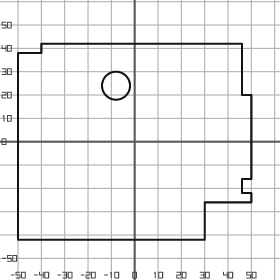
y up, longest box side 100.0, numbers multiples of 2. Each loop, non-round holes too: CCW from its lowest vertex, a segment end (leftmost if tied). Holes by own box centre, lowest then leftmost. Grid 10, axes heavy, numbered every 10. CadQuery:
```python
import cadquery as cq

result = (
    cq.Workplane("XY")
    .moveTo(-50.0, -42.0)
    .lineTo(30.0, -42.0)
    .lineTo(30.0, -26.0)
    .lineTo(50.0, -26.0)
    .lineTo(50.0, -22.0)
    .lineTo(46.0, -22.0)
    .lineTo(46.0, -16.0)
    .lineTo(50.0, -16.0)
    .lineTo(50.0, 20.0)
    .lineTo(46.0, 20.0)
    .lineTo(46.0, 42.0)
    .lineTo(-40.0, 42.0)
    .lineTo(-40.0, 38.0)
    .lineTo(-50.0, 38.0)
    .close()
    .moveTo(-8.0, 24.0)
    .circle(6.0)
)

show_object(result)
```